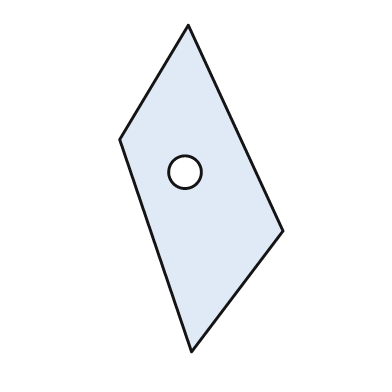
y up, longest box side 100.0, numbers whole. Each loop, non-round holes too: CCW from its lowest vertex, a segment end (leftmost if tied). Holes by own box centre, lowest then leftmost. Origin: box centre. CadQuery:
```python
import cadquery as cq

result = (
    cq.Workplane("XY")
    .moveTo(-3.0, -50.0)
    .lineTo(25.0, -13.0)
    .lineTo(-4.0, 50.0)
    .lineTo(-25.0, 15.0)
    .close()
    .moveTo(-5.0, 5.0)
    .circle(5.0)
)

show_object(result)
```